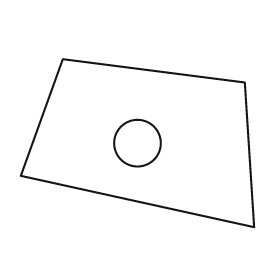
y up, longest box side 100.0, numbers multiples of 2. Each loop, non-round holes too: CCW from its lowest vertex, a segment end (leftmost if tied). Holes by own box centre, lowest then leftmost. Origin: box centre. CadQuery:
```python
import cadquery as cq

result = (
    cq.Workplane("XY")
    .moveTo(50.0, -36.0)
    .lineTo(46.0, 26.0)
    .lineTo(-32.0, 36.0)
    .lineTo(-50.0, -14.0)
    .close()
    .moveTo(0.0, 0.0)
    .circle(10.0)
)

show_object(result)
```